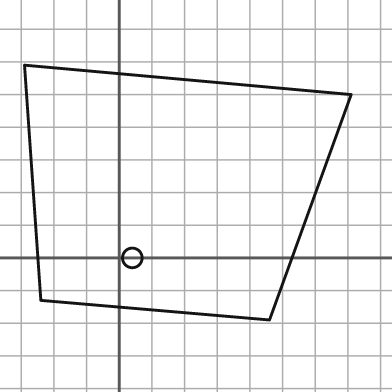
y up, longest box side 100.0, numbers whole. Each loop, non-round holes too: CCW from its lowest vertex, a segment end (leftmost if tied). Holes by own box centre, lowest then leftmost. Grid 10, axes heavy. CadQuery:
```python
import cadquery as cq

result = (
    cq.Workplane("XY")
    .moveTo(46.0, -19.0)
    .lineTo(71.0, 50.0)
    .lineTo(-29.0, 59.0)
    .lineTo(-24.0, -13.0)
    .close()
    .moveTo(4.0, 0.0)
    .circle(3.0)
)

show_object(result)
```